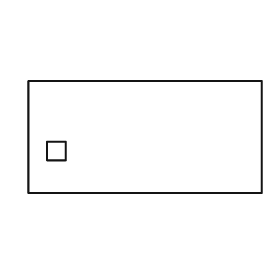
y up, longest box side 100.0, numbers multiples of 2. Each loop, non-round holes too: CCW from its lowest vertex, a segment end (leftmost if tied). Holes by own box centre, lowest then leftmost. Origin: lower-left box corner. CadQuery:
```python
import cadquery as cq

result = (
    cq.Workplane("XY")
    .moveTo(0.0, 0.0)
    .lineTo(100.0, 0.0)
    .lineTo(100.0, 48.0)
    .lineTo(0.0, 48.0)
    .close()
    .moveTo(8.0, 14.0)
    .lineTo(16.0, 14.0)
    .lineTo(16.0, 22.0)
    .lineTo(8.0, 22.0)
    .close()
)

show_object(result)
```